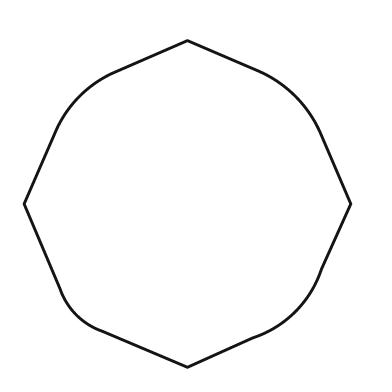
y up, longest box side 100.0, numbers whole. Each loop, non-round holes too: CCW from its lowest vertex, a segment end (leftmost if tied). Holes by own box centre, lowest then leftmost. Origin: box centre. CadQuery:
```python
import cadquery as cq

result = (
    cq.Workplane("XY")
    .moveTo(0.0, -50.0)
    .lineTo(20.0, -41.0)
    .threePointArc((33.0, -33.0), (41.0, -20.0))
    .lineTo(50.0, 0.0)
    .lineTo(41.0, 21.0)
    .threePointArc((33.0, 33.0), (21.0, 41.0))
    .lineTo(0.0, 50.0)
    .lineTo(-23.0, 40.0)
    .threePointArc((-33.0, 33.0), (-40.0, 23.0))
    .lineTo(-50.0, 0.0)
    .lineTo(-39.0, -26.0)
    .threePointArc((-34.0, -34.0), (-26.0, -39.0))
    .close()
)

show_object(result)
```